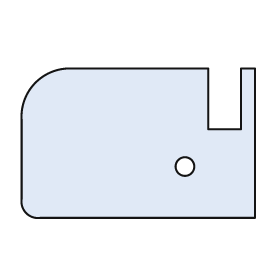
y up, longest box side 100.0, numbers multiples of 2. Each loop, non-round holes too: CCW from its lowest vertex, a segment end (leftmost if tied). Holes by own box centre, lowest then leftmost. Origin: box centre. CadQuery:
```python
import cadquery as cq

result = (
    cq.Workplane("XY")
    .moveTo(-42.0, -32.0)
    .lineTo(50.0, -32.0)
    .lineTo(50.0, 32.0)
    .lineTo(44.0, 32.0)
    .lineTo(44.0, 6.0)
    .lineTo(30.0, 6.0)
    .lineTo(30.0, 32.0)
    .lineTo(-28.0, 32.0)
    .threePointArc((-44.0, 26.0), (-50.0, 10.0))
    .lineTo(-50.0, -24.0)
    .threePointArc((-48.0, -30.0), (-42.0, -32.0))
    .close()
    .moveTo(20.0, -10.0)
    .circle(4.0)
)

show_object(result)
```